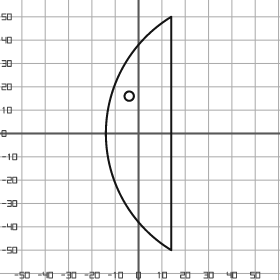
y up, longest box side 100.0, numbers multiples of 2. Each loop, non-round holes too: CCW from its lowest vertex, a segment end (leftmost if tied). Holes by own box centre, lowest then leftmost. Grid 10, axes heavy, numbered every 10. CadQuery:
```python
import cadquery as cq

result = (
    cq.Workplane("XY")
    .moveTo(14.0, -50.0)
    .lineTo(14.0, 50.0)
    .threePointArc((-14.0, 0.0), (14.0, -50.0))
    .close()
    .moveTo(-4.0, 16.0)
    .circle(2.0)
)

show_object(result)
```